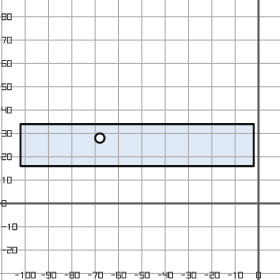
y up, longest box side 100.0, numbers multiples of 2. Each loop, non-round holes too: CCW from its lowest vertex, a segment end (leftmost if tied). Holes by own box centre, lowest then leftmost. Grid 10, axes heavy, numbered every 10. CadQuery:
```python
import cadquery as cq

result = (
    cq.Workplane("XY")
    .moveTo(-102.0, 16.0)
    .lineTo(-2.0, 16.0)
    .lineTo(-2.0, 34.0)
    .lineTo(-102.0, 34.0)
    .close()
    .moveTo(-68.0, 28.0)
    .circle(2.0)
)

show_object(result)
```